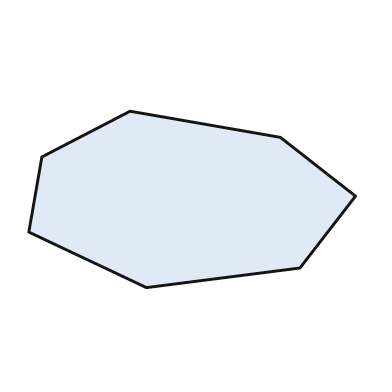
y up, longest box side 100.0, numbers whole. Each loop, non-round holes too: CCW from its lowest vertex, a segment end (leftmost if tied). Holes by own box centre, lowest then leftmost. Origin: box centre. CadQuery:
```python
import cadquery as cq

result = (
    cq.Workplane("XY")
    .moveTo(-14.0, -27.0)
    .lineTo(33.0, -21.0)
    .lineTo(50.0, 1.0)
    .lineTo(27.0, 19.0)
    .lineTo(-19.0, 27.0)
    .lineTo(-46.0, 13.0)
    .lineTo(-50.0, -10.0)
    .close()
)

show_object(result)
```